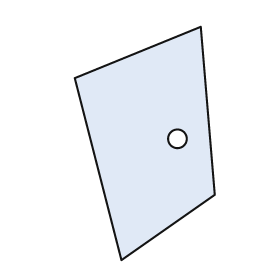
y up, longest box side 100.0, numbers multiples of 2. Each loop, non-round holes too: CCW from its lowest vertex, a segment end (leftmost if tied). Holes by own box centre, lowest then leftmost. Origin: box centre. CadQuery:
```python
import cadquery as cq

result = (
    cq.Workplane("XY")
    .moveTo(-10.0, -50.0)
    .lineTo(30.0, -22.0)
    .lineTo(24.0, 50.0)
    .lineTo(-30.0, 28.0)
    .close()
    .moveTo(14.0, 2.0)
    .circle(4.0)
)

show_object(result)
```